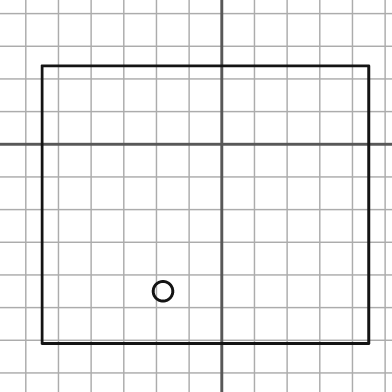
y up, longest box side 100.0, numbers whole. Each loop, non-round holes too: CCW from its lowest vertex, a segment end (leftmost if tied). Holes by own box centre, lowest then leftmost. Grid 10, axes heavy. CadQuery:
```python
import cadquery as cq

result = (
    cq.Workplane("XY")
    .moveTo(-55.0, -61.0)
    .lineTo(45.0, -61.0)
    .lineTo(45.0, 24.0)
    .lineTo(-55.0, 24.0)
    .close()
    .moveTo(-18.0, -45.0)
    .circle(3.0)
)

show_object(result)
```